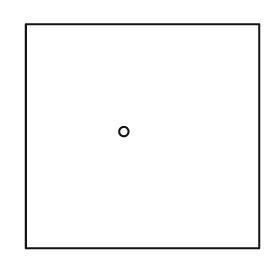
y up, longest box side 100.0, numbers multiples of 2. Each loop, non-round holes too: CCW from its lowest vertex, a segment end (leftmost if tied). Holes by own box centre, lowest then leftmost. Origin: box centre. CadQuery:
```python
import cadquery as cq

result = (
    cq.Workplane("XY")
    .moveTo(-50.0, -48.0)
    .lineTo(50.0, -48.0)
    .lineTo(50.0, 48.0)
    .lineTo(-50.0, 48.0)
    .close()
    .moveTo(-8.0, 2.0)
    .circle(2.0)
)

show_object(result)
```